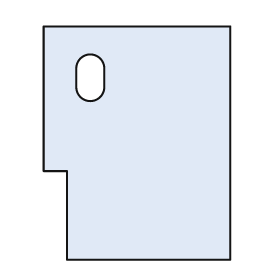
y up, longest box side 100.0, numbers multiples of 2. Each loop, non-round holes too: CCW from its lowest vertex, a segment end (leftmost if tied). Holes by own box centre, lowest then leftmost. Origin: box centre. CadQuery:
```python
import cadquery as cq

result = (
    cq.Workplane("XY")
    .moveTo(-30.0, -50.0)
    .lineTo(40.0, -50.0)
    .lineTo(40.0, 50.0)
    .lineTo(-40.0, 50.0)
    .lineTo(-40.0, -12.0)
    .lineTo(-30.0, -12.0)
    .close()
    .moveTo(-26.0, 24.0)
    .threePointArc((-20.0, 18.0), (-14.0, 24.0))
    .lineTo(-14.0, 32.0)
    .threePointArc((-20.0, 38.0), (-26.0, 32.0))
    .close()
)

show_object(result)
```